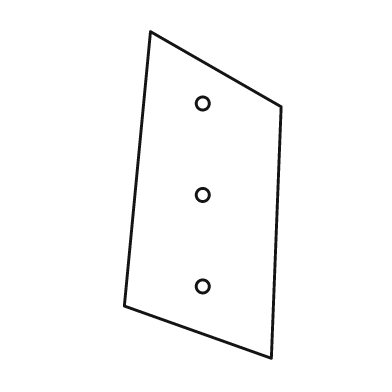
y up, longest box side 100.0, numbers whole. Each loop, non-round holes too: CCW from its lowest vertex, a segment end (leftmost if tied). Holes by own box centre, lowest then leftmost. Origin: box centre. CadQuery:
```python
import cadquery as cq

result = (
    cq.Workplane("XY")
    .moveTo(21.0, -50.0)
    .lineTo(24.0, 27.0)
    .lineTo(-16.0, 50.0)
    .lineTo(-24.0, -34.0)
    .close()
    .moveTo(0.0, -28.0)
    .circle(2.0)
    .moveTo(0.0, 0.0)
    .circle(2.0)
    .moveTo(0.0, 28.0)
    .circle(2.0)
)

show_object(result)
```